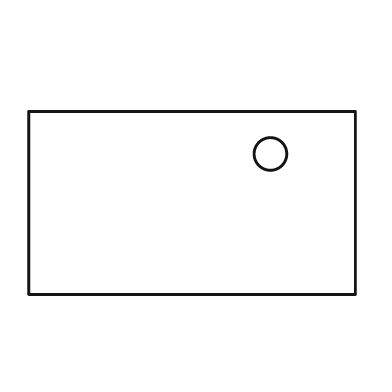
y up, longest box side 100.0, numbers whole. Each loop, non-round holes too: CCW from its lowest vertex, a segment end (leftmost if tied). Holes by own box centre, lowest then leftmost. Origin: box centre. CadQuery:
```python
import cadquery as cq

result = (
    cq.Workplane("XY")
    .moveTo(-50.0, -28.0)
    .lineTo(50.0, -28.0)
    .lineTo(50.0, 28.0)
    .lineTo(-50.0, 28.0)
    .close()
    .moveTo(24.0, 15.0)
    .circle(5.0)
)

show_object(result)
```